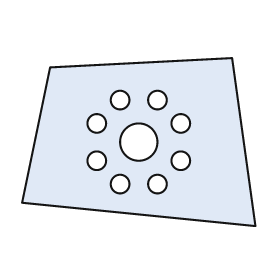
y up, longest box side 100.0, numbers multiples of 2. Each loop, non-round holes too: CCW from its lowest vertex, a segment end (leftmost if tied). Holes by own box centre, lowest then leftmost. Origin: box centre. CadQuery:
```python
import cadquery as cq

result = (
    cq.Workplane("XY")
    .moveTo(50.0, -36.0)
    .lineTo(40.0, 36.0)
    .lineTo(-38.0, 32.0)
    .lineTo(-50.0, -26.0)
    .close()
    .moveTo(-8.0, -18.0)
    .circle(4.0)
    .moveTo(8.0, -18.0)
    .circle(4.0)
    .moveTo(-18.0, -8.0)
    .circle(4.0)
    .moveTo(18.0, -8.0)
    .circle(4.0)
    .moveTo(0.0, 0.0)
    .circle(8.0)
    .moveTo(-18.0, 8.0)
    .circle(4.0)
    .moveTo(18.0, 8.0)
    .circle(4.0)
    .moveTo(-8.0, 18.0)
    .circle(4.0)
    .moveTo(8.0, 18.0)
    .circle(4.0)
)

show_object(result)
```